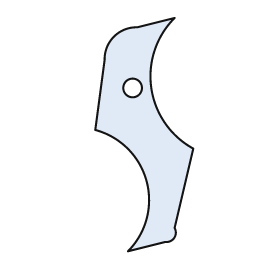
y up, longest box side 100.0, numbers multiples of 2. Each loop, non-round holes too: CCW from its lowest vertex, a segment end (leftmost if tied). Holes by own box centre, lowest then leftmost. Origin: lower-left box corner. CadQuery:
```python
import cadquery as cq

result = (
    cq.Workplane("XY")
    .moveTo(14.0, 0.0)
    .lineTo(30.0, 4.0)
    .threePointArc((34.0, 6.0), (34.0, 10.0))
    .lineTo(42.0, 44.0)
    .threePointArc((24.0, 70.0), (34.0, 100.0))
    .lineTo(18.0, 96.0)
    .threePointArc((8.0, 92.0), (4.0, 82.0))
    .lineTo(0.0, 52.0)
    .threePointArc((22.0, 30.0), (14.0, 0.0))
    .close()
    .moveTo(16.0, 70.0)
    .circle(4.0)
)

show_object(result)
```